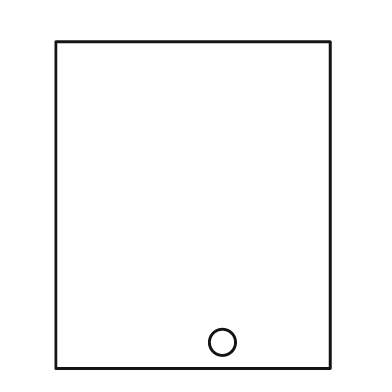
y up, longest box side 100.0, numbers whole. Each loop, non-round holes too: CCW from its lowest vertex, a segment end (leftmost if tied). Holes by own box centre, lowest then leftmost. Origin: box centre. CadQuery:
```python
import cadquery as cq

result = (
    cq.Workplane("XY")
    .moveTo(-42.0, -50.0)
    .lineTo(42.0, -50.0)
    .lineTo(42.0, 50.0)
    .lineTo(-42.0, 50.0)
    .close()
    .moveTo(9.0, -42.0)
    .circle(4.0)
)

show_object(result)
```